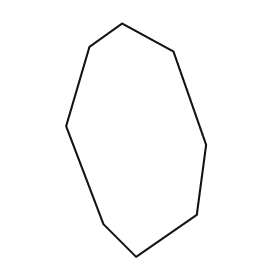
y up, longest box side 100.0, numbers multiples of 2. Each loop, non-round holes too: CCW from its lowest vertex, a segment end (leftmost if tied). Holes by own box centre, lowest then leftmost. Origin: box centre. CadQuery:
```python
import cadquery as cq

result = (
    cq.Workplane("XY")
    .moveTo(0.0, -50.0)
    .lineTo(26.0, -32.0)
    .lineTo(30.0, -2.0)
    .lineTo(16.0, 38.0)
    .lineTo(-6.0, 50.0)
    .lineTo(-20.0, 40.0)
    .lineTo(-30.0, 6.0)
    .lineTo(-14.0, -36.0)
    .close()
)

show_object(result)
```